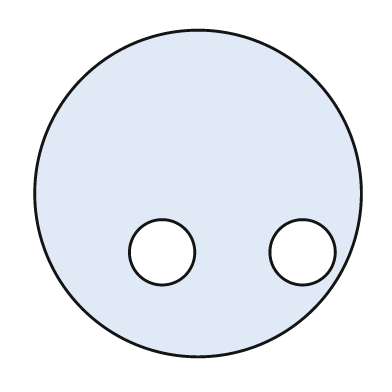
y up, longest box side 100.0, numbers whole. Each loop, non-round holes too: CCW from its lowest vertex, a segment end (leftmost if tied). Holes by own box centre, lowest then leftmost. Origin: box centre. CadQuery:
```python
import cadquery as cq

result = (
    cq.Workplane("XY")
    .moveTo(0.0, 0.0)
    .circle(50.0)
    .moveTo(-11.0, -18.0)
    .circle(10.0)
    .moveTo(32.0, -18.0)
    .circle(10.0)
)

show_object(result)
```